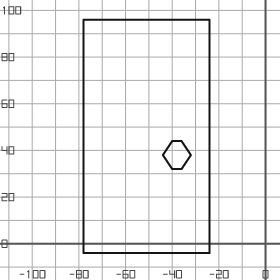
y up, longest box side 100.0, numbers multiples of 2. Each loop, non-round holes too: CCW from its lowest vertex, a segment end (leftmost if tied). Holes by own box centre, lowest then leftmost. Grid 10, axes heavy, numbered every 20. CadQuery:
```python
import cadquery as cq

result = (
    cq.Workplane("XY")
    .moveTo(-78.0, -4.0)
    .lineTo(-24.0, -4.0)
    .lineTo(-24.0, 96.0)
    .lineTo(-78.0, 96.0)
    .close()
    .moveTo(-40.0, 32.0)
    .lineTo(-36.0, 32.0)
    .lineTo(-32.0, 38.0)
    .lineTo(-36.0, 44.0)
    .lineTo(-40.0, 44.0)
    .lineTo(-44.0, 38.0)
    .close()
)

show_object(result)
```